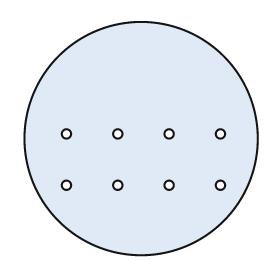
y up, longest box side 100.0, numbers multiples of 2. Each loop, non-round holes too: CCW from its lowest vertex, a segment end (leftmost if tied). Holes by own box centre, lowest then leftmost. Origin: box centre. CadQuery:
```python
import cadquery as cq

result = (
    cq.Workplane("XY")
    .moveTo(0.0, 0.0)
    .circle(50.0)
    .moveTo(-32.0, -20.0)
    .circle(2.0)
    .moveTo(-10.0, -20.0)
    .circle(2.0)
    .moveTo(12.0, -20.0)
    .circle(2.0)
    .moveTo(34.0, -20.0)
    .circle(2.0)
    .moveTo(-32.0, 2.0)
    .circle(2.0)
    .moveTo(-10.0, 2.0)
    .circle(2.0)
    .moveTo(12.0, 2.0)
    .circle(2.0)
    .moveTo(34.0, 2.0)
    .circle(2.0)
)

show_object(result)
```